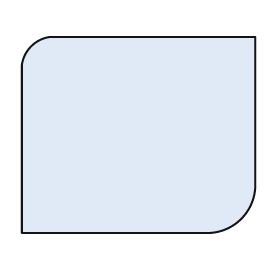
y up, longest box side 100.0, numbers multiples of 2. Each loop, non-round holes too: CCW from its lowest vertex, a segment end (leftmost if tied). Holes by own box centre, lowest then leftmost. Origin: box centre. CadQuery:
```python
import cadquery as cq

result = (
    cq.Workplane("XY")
    .moveTo(-50.0, -42.0)
    .lineTo(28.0, -42.0)
    .threePointArc((44.0, -36.0), (50.0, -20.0))
    .lineTo(50.0, 42.0)
    .lineTo(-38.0, 42.0)
    .threePointArc((-46.0, 38.0), (-50.0, 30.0))
    .close()
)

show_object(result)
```